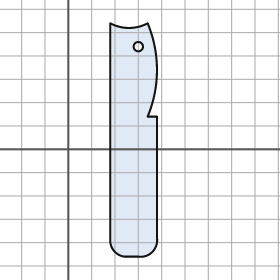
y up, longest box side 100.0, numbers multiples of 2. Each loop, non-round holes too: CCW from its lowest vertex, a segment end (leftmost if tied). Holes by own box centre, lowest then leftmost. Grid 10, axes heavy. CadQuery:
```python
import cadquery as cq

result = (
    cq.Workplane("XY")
    .moveTo(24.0, -46.0)
    .lineTo(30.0, -46.0)
    .threePointArc((36.0, -44.0), (38.0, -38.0))
    .lineTo(38.0, 14.0)
    .lineTo(34.0, 14.0)
    .threePointArc((38.0, 34.0), (34.0, 54.0))
    .threePointArc((26.0, 52.0), (18.0, 54.0))
    .lineTo(18.0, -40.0)
    .threePointArc((20.0, -44.0), (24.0, -46.0))
    .close()
    .moveTo(30.0, 44.0)
    .circle(2.0)
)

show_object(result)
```